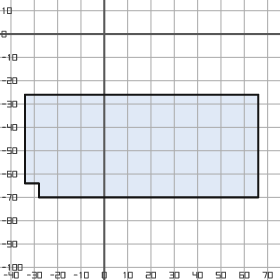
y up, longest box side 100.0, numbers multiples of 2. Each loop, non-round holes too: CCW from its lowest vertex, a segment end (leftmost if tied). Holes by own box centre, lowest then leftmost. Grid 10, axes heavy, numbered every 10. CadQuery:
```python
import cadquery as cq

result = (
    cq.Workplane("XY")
    .moveTo(-28.0, -70.0)
    .lineTo(66.0, -70.0)
    .lineTo(66.0, -26.0)
    .lineTo(-34.0, -26.0)
    .lineTo(-34.0, -64.0)
    .lineTo(-28.0, -64.0)
    .close()
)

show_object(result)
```